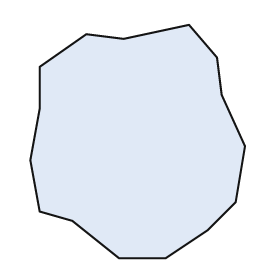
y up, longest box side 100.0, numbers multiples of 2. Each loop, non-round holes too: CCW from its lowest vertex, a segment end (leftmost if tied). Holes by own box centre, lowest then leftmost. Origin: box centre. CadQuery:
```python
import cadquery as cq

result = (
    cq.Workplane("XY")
    .moveTo(-8.0, -50.0)
    .lineTo(12.0, -50.0)
    .lineTo(30.0, -38.0)
    .lineTo(42.0, -26.0)
    .lineTo(46.0, -2.0)
    .lineTo(36.0, 20.0)
    .lineTo(34.0, 36.0)
    .lineTo(22.0, 50.0)
    .lineTo(-6.0, 44.0)
    .lineTo(-22.0, 46.0)
    .lineTo(-42.0, 32.0)
    .lineTo(-42.0, 14.0)
    .lineTo(-46.0, -8.0)
    .lineTo(-42.0, -30.0)
    .lineTo(-28.0, -34.0)
    .close()
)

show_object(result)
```